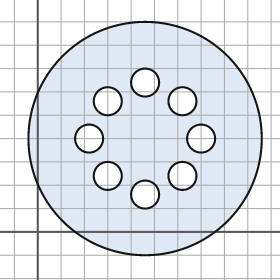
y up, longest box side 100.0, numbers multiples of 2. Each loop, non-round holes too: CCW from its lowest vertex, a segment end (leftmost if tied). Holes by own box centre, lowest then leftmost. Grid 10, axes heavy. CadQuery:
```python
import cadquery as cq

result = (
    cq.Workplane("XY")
    .moveTo(46.0, 40.0)
    .circle(50.0)
    .moveTo(46.0, 16.0)
    .circle(6.0)
    .moveTo(30.0, 24.0)
    .circle(6.0)
    .moveTo(62.0, 24.0)
    .circle(6.0)
    .moveTo(22.0, 40.0)
    .circle(6.0)
    .moveTo(70.0, 40.0)
    .circle(6.0)
    .moveTo(30.0, 56.0)
    .circle(6.0)
    .moveTo(62.0, 56.0)
    .circle(6.0)
    .moveTo(46.0, 64.0)
    .circle(6.0)
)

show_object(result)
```